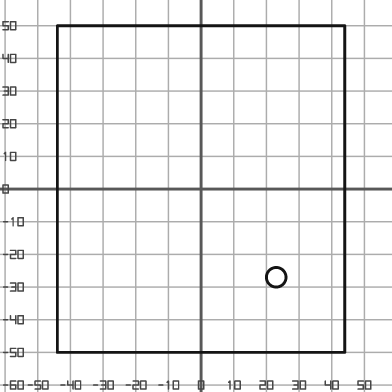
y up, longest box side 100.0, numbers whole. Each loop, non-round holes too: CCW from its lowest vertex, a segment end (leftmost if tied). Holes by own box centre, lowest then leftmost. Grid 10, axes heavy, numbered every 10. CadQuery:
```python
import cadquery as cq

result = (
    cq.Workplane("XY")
    .moveTo(-44.0, -50.0)
    .lineTo(44.0, -50.0)
    .lineTo(44.0, 50.0)
    .lineTo(-44.0, 50.0)
    .close()
    .moveTo(23.0, -27.0)
    .circle(3.0)
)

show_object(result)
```